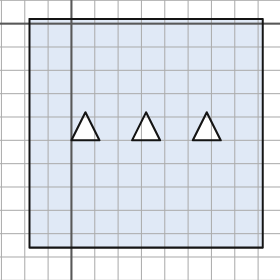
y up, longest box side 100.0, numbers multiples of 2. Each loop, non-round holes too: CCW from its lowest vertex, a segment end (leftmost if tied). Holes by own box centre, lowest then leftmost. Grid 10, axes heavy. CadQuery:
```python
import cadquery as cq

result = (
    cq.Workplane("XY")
    .moveTo(-18.0, -96.0)
    .lineTo(82.0, -96.0)
    .lineTo(82.0, 2.0)
    .lineTo(-18.0, 2.0)
    .close()
    .moveTo(0.0, -50.0)
    .lineTo(12.0, -50.0)
    .lineTo(6.0, -38.0)
    .close()
    .moveTo(26.0, -50.0)
    .lineTo(38.0, -50.0)
    .lineTo(32.0, -38.0)
    .close()
    .moveTo(52.0, -50.0)
    .lineTo(64.0, -50.0)
    .lineTo(58.0, -38.0)
    .close()
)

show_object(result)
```